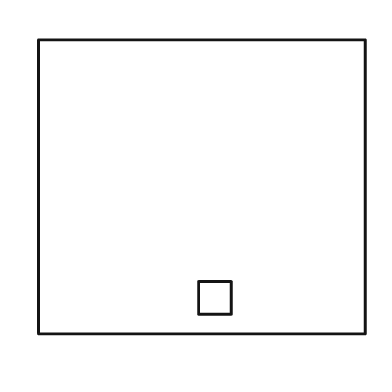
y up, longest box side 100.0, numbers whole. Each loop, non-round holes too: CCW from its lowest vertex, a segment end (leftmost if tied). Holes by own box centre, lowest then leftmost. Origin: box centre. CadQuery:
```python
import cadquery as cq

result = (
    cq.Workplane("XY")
    .moveTo(-50.0, -45.0)
    .lineTo(50.0, -45.0)
    .lineTo(50.0, 45.0)
    .lineTo(-50.0, 45.0)
    .close()
    .moveTo(-1.0, -39.0)
    .lineTo(9.0, -39.0)
    .lineTo(9.0, -29.0)
    .lineTo(-1.0, -29.0)
    .close()
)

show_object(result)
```